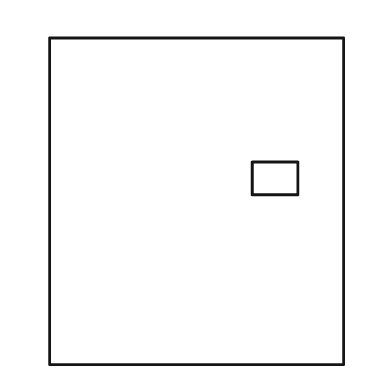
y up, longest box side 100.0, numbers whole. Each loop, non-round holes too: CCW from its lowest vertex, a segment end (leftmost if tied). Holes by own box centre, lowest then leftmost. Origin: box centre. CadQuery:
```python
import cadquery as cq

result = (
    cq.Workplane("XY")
    .moveTo(-45.0, -50.0)
    .lineTo(45.0, -50.0)
    .lineTo(45.0, 50.0)
    .lineTo(-45.0, 50.0)
    .close()
    .moveTo(17.0, 2.0)
    .lineTo(31.0, 2.0)
    .lineTo(31.0, 12.0)
    .lineTo(17.0, 12.0)
    .close()
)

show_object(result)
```